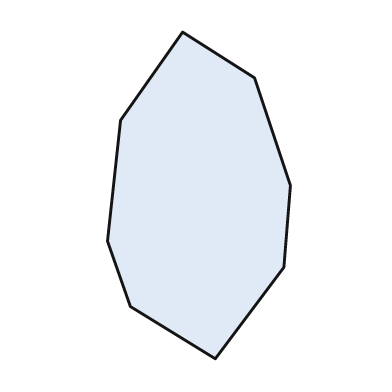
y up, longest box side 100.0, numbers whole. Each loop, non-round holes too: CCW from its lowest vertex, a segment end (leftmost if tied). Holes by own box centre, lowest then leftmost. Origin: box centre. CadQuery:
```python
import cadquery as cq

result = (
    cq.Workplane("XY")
    .moveTo(5.0, -50.0)
    .lineTo(26.0, -22.0)
    .lineTo(28.0, 3.0)
    .lineTo(17.0, 36.0)
    .lineTo(-5.0, 50.0)
    .lineTo(-24.0, 23.0)
    .lineTo(-28.0, -14.0)
    .lineTo(-21.0, -34.0)
    .close()
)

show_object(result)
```